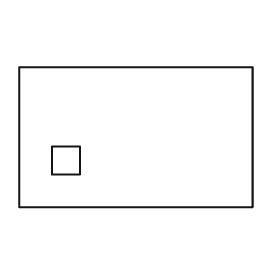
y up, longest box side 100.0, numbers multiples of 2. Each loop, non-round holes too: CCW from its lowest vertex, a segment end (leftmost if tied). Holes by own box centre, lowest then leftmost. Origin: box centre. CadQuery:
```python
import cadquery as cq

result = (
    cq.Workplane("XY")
    .moveTo(-50.0, -30.0)
    .lineTo(50.0, -30.0)
    .lineTo(50.0, 30.0)
    .lineTo(-50.0, 30.0)
    .close()
    .moveTo(-36.0, -16.0)
    .lineTo(-24.0, -16.0)
    .lineTo(-24.0, -4.0)
    .lineTo(-36.0, -4.0)
    .close()
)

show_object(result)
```